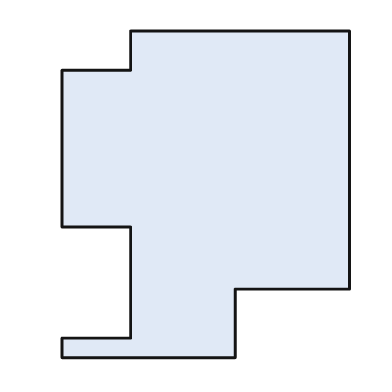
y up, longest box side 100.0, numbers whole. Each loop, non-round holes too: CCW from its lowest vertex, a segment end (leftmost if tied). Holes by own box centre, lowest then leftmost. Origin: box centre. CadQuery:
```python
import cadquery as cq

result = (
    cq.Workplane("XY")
    .moveTo(-44.0, -50.0)
    .lineTo(9.0, -50.0)
    .lineTo(9.0, -29.0)
    .lineTo(44.0, -29.0)
    .lineTo(44.0, 50.0)
    .lineTo(-23.0, 50.0)
    .lineTo(-23.0, 38.0)
    .lineTo(-44.0, 38.0)
    .lineTo(-44.0, -10.0)
    .lineTo(-23.0, -10.0)
    .lineTo(-23.0, -44.0)
    .lineTo(-44.0, -44.0)
    .close()
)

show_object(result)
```